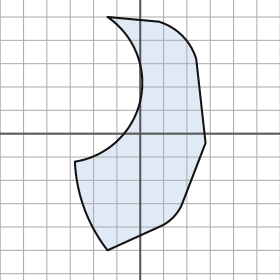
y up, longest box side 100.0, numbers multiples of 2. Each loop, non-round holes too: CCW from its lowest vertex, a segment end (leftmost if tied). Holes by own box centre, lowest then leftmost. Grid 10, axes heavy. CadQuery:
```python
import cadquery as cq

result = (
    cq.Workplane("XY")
    .moveTo(-14.0, -50.0)
    .lineTo(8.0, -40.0)
    .threePointArc((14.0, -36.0), (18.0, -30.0))
    .lineTo(28.0, -4.0)
    .lineTo(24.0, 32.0)
    .threePointArc((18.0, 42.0), (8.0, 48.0))
    .lineTo(-14.0, 50.0)
    .threePointArc((0.0, 14.0), (-28.0, -12.0))
    .threePointArc((-24.0, -32.0), (-14.0, -50.0))
    .close()
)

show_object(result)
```